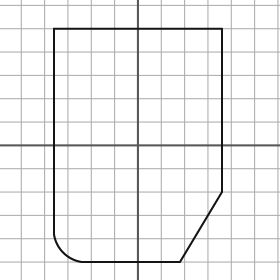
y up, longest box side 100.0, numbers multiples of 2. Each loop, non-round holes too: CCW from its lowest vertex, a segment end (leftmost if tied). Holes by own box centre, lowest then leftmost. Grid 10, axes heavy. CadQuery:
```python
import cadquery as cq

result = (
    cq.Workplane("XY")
    .moveTo(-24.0, -50.0)
    .lineTo(18.0, -50.0)
    .lineTo(36.0, -20.0)
    .lineTo(36.0, 50.0)
    .lineTo(-36.0, 50.0)
    .lineTo(-36.0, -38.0)
    .threePointArc((-32.0, -46.0), (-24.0, -50.0))
    .close()
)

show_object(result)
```